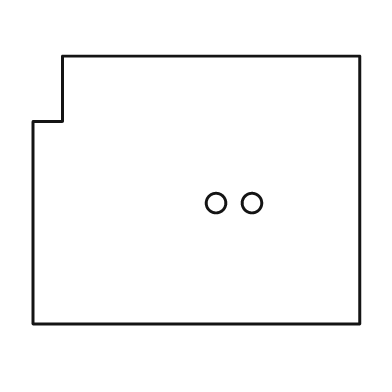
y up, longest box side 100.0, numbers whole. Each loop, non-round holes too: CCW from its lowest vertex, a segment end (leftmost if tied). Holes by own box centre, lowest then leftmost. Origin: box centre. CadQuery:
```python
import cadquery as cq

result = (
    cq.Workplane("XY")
    .moveTo(-50.0, -41.0)
    .lineTo(50.0, -41.0)
    .lineTo(50.0, 41.0)
    .lineTo(-41.0, 41.0)
    .lineTo(-41.0, 21.0)
    .lineTo(-50.0, 21.0)
    .close()
    .moveTo(6.0, -4.0)
    .circle(3.0)
    .moveTo(17.0, -4.0)
    .circle(3.0)
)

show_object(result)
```